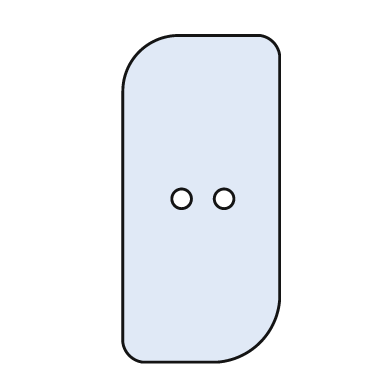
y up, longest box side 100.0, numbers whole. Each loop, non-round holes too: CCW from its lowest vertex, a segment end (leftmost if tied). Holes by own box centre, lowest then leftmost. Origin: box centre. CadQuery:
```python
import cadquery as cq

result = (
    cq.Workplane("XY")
    .moveTo(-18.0, -50.0)
    .lineTo(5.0, -50.0)
    .threePointArc((18.0, -44.0), (24.0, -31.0))
    .lineTo(24.0, 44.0)
    .threePointArc((22.0, 48.0), (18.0, 50.0))
    .lineTo(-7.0, 50.0)
    .threePointArc((-19.0, 45.0), (-24.0, 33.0))
    .lineTo(-24.0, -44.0)
    .threePointArc((-22.0, -48.0), (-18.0, -50.0))
    .close()
    .moveTo(-6.0, 0.0)
    .circle(3.0)
    .moveTo(7.0, 0.0)
    .circle(3.0)
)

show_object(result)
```